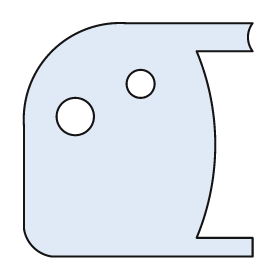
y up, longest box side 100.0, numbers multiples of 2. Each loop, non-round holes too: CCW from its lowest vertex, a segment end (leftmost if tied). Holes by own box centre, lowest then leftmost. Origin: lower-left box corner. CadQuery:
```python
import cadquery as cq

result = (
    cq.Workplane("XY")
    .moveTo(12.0, 0.0)
    .lineTo(98.0, 0.0)
    .lineTo(98.0, 8.0)
    .lineTo(74.0, 8.0)
    .threePointArc((82.0, 48.0), (74.0, 88.0))
    .lineTo(98.0, 88.0)
    .threePointArc((96.0, 94.0), (98.0, 100.0))
    .lineTo(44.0, 100.0)
    .threePointArc((12.0, 88.0), (0.0, 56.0))
    .lineTo(0.0, 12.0)
    .threePointArc((4.0, 4.0), (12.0, 0.0))
    .close()
    .moveTo(22.0, 60.0)
    .circle(8.0)
    .moveTo(50.0, 74.0)
    .circle(6.0)
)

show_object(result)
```